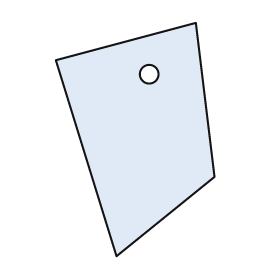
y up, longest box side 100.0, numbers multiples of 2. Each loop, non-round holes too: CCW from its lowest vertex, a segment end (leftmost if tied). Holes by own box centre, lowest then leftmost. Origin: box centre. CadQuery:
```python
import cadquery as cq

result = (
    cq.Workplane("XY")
    .moveTo(-8.0, -50.0)
    .lineTo(34.0, -16.0)
    .lineTo(26.0, 50.0)
    .lineTo(-34.0, 34.0)
    .close()
    .moveTo(6.0, 28.0)
    .circle(4.0)
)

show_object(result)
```